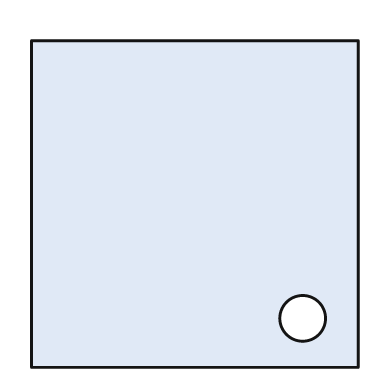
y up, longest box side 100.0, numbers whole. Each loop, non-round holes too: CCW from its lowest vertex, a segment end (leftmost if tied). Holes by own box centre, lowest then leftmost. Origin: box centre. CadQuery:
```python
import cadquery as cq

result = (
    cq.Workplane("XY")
    .moveTo(-50.0, -50.0)
    .lineTo(50.0, -50.0)
    .lineTo(50.0, 50.0)
    .lineTo(-50.0, 50.0)
    .close()
    .moveTo(33.0, -35.0)
    .circle(7.0)
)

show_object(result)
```